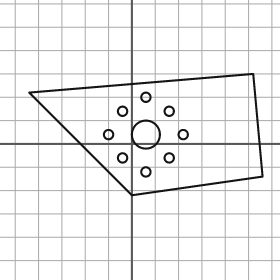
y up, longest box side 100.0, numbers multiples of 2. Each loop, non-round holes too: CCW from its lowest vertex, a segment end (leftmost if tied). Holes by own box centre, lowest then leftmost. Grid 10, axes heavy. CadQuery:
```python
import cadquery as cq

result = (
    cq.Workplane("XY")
    .moveTo(0.0, -22.0)
    .lineTo(56.0, -14.0)
    .lineTo(52.0, 30.0)
    .lineTo(-44.0, 22.0)
    .close()
    .moveTo(6.0, -12.0)
    .circle(2.0)
    .moveTo(-4.0, -6.0)
    .circle(2.0)
    .moveTo(16.0, -6.0)
    .circle(2.0)
    .moveTo(-10.0, 4.0)
    .circle(2.0)
    .moveTo(6.0, 4.0)
    .circle(6.0)
    .moveTo(22.0, 4.0)
    .circle(2.0)
    .moveTo(-4.0, 14.0)
    .circle(2.0)
    .moveTo(16.0, 14.0)
    .circle(2.0)
    .moveTo(6.0, 20.0)
    .circle(2.0)
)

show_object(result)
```